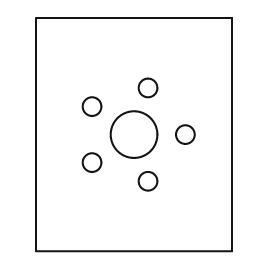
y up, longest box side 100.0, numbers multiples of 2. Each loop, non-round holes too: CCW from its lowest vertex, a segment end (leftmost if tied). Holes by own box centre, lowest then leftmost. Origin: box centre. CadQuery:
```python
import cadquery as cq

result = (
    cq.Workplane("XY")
    .moveTo(-42.0, -50.0)
    .lineTo(42.0, -50.0)
    .lineTo(42.0, 50.0)
    .lineTo(-42.0, 50.0)
    .close()
    .moveTo(6.0, -20.0)
    .circle(4.0)
    .moveTo(-18.0, -12.0)
    .circle(4.0)
    .moveTo(0.0, 0.0)
    .circle(10.0)
    .moveTo(22.0, 0.0)
    .circle(4.0)
    .moveTo(-18.0, 12.0)
    .circle(4.0)
    .moveTo(6.0, 20.0)
    .circle(4.0)
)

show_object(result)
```